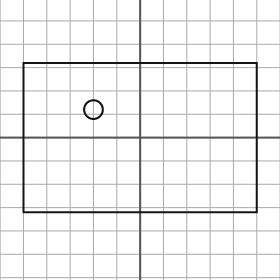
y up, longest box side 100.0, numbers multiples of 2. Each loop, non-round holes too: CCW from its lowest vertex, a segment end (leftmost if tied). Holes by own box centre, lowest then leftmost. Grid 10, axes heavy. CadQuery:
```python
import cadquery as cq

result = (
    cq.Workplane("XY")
    .moveTo(-50.0, -32.0)
    .lineTo(50.0, -32.0)
    .lineTo(50.0, 32.0)
    .lineTo(-50.0, 32.0)
    .close()
    .moveTo(-20.0, 12.0)
    .circle(4.0)
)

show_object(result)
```